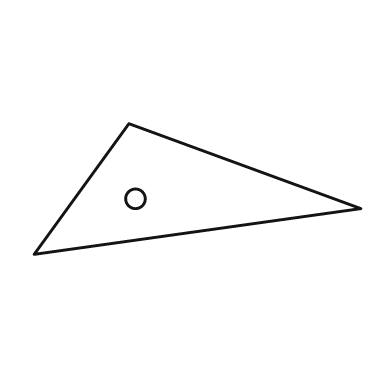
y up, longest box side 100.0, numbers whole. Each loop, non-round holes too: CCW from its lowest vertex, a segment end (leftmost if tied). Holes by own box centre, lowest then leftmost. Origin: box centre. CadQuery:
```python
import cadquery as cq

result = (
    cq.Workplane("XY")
    .moveTo(-50.0, -20.0)
    .lineTo(50.0, -6.0)
    .lineTo(-21.0, 20.0)
    .close()
    .moveTo(-19.0, -3.0)
    .circle(3.0)
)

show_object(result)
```